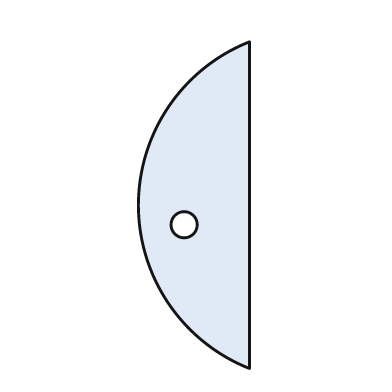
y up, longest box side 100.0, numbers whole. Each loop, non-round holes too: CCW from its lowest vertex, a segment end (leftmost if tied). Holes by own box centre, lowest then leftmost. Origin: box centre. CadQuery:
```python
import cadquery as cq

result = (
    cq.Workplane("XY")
    .moveTo(17.0, -50.0)
    .lineTo(17.0, 50.0)
    .threePointArc((-17.0, 0.0), (17.0, -50.0))
    .close()
    .moveTo(-3.0, -6.0)
    .circle(4.0)
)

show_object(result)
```